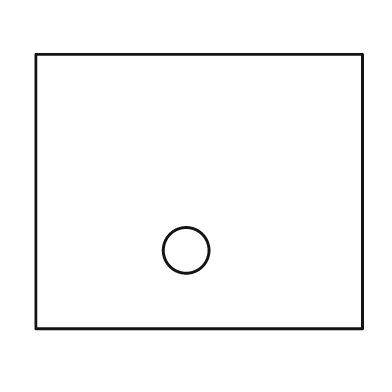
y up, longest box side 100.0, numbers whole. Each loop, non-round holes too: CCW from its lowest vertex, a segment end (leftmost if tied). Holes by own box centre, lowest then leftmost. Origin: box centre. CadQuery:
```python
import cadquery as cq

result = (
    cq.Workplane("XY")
    .moveTo(-50.0, -42.0)
    .lineTo(50.0, -42.0)
    .lineTo(50.0, 42.0)
    .lineTo(-50.0, 42.0)
    .close()
    .moveTo(-4.0, -18.0)
    .circle(7.0)
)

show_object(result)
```